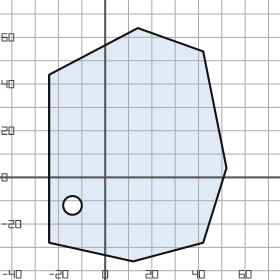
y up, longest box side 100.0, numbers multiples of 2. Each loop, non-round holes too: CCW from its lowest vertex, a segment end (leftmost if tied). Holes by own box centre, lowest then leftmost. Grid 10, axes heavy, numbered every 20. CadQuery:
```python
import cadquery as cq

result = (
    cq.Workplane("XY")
    .moveTo(12.0, -36.0)
    .lineTo(42.0, -28.0)
    .lineTo(52.0, 4.0)
    .lineTo(42.0, 54.0)
    .lineTo(14.0, 64.0)
    .lineTo(-24.0, 44.0)
    .lineTo(-24.0, -28.0)
    .close()
    .moveTo(-14.0, -12.0)
    .circle(4.0)
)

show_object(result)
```